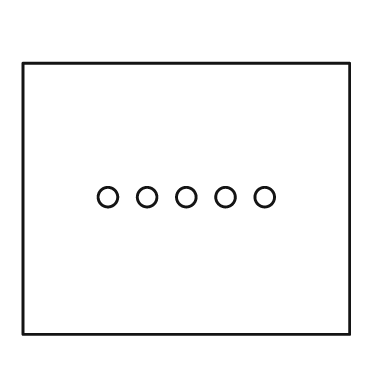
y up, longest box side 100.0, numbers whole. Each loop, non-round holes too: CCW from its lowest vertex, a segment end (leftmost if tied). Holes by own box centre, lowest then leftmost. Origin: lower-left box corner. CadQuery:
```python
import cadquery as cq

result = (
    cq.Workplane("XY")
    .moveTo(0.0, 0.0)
    .lineTo(100.0, 0.0)
    .lineTo(100.0, 83.0)
    .lineTo(0.0, 83.0)
    .close()
    .moveTo(26.0, 42.0)
    .circle(3.0)
    .moveTo(38.0, 42.0)
    .circle(3.0)
    .moveTo(50.0, 42.0)
    .circle(3.0)
    .moveTo(62.0, 42.0)
    .circle(3.0)
    .moveTo(74.0, 42.0)
    .circle(3.0)
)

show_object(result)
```